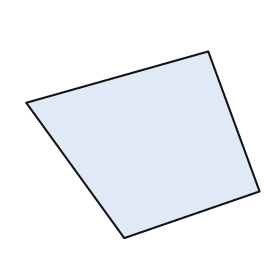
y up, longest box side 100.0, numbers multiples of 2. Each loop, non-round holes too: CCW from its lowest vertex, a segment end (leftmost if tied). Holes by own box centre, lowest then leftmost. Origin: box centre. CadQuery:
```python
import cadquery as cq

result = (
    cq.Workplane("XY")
    .moveTo(-8.0, -40.0)
    .lineTo(50.0, -20.0)
    .lineTo(28.0, 40.0)
    .lineTo(-50.0, 18.0)
    .close()
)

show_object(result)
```